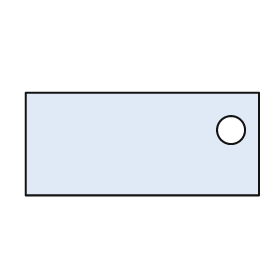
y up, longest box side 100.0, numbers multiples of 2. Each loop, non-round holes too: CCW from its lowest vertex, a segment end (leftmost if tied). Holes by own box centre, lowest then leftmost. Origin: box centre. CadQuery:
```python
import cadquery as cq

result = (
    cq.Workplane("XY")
    .moveTo(-50.0, -22.0)
    .lineTo(50.0, -22.0)
    .lineTo(50.0, 22.0)
    .lineTo(-50.0, 22.0)
    .close()
    .moveTo(38.0, 6.0)
    .circle(6.0)
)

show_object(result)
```